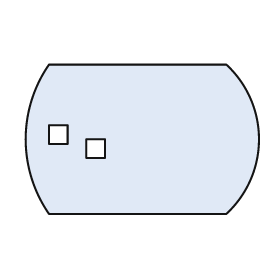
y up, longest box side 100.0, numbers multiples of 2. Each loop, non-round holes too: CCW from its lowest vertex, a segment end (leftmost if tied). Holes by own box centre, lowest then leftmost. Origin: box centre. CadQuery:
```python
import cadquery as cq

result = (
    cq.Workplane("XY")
    .moveTo(-40.0, -32.0)
    .lineTo(36.0, -32.0)
    .threePointArc((50.0, 0.0), (36.0, 32.0))
    .lineTo(-40.0, 32.0)
    .threePointArc((-50.0, 0.0), (-40.0, -32.0))
    .close()
    .moveTo(-24.0, -8.0)
    .lineTo(-16.0, -8.0)
    .lineTo(-16.0, 0.0)
    .lineTo(-24.0, 0.0)
    .close()
    .moveTo(-40.0, -2.0)
    .lineTo(-32.0, -2.0)
    .lineTo(-32.0, 6.0)
    .lineTo(-40.0, 6.0)
    .close()
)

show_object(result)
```